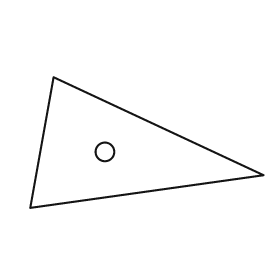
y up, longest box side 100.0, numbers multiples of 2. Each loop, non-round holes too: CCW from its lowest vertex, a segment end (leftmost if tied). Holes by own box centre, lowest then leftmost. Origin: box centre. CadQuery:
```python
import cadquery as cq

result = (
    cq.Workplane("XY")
    .moveTo(-50.0, -28.0)
    .lineTo(50.0, -14.0)
    .lineTo(-40.0, 28.0)
    .close()
    .moveTo(-18.0, -4.0)
    .circle(4.0)
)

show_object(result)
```